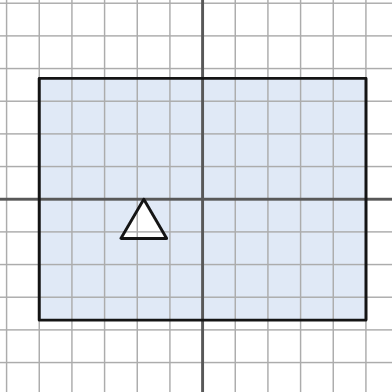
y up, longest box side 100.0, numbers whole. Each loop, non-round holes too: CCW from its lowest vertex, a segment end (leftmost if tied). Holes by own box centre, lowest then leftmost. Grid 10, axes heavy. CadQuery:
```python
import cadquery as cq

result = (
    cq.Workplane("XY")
    .moveTo(-50.0, -37.0)
    .lineTo(50.0, -37.0)
    .lineTo(50.0, 37.0)
    .lineTo(-50.0, 37.0)
    .close()
    .moveTo(-25.0, -12.0)
    .lineTo(-11.0, -12.0)
    .lineTo(-18.0, 0.0)
    .close()
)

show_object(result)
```